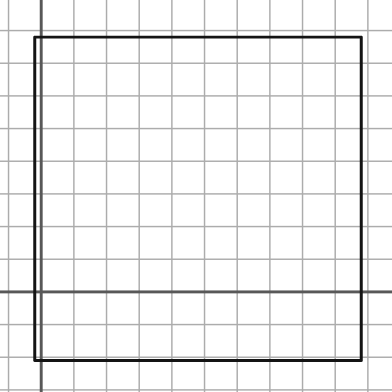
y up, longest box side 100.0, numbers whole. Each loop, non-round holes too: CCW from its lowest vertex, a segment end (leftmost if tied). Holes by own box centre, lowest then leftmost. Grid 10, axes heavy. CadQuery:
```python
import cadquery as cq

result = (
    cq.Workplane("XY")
    .moveTo(-2.0, -21.0)
    .lineTo(98.0, -21.0)
    .lineTo(98.0, 78.0)
    .lineTo(-2.0, 78.0)
    .close()
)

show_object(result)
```